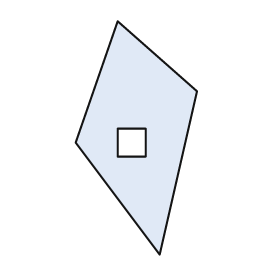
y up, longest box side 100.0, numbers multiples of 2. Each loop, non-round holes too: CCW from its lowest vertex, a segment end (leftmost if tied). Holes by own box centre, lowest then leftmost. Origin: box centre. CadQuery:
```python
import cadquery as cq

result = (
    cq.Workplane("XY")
    .moveTo(10.0, -50.0)
    .lineTo(26.0, 20.0)
    .lineTo(-8.0, 50.0)
    .lineTo(-26.0, -2.0)
    .close()
    .moveTo(-8.0, -8.0)
    .lineTo(4.0, -8.0)
    .lineTo(4.0, 4.0)
    .lineTo(-8.0, 4.0)
    .close()
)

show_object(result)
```